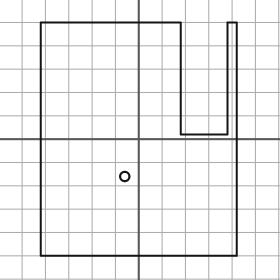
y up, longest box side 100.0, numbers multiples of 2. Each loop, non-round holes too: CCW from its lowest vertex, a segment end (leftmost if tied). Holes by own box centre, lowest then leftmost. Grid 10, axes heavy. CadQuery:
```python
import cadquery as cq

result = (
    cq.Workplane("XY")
    .moveTo(-42.0, -50.0)
    .lineTo(42.0, -50.0)
    .lineTo(42.0, 50.0)
    .lineTo(38.0, 50.0)
    .lineTo(38.0, 2.0)
    .lineTo(18.0, 2.0)
    .lineTo(18.0, 50.0)
    .lineTo(-42.0, 50.0)
    .close()
    .moveTo(-6.0, -16.0)
    .circle(2.0)
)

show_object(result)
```